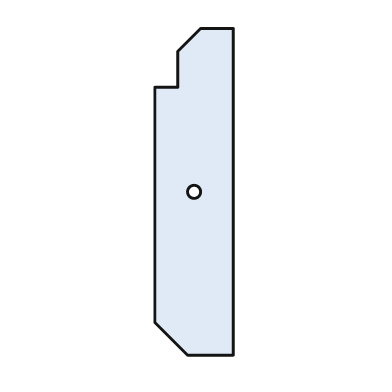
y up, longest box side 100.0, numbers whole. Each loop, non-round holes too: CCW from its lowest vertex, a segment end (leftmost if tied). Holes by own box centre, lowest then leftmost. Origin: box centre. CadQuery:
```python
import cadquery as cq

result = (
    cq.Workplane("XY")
    .moveTo(-2.0, -50.0)
    .lineTo(12.0, -50.0)
    .lineTo(12.0, 50.0)
    .lineTo(2.0, 50.0)
    .lineTo(-5.0, 43.0)
    .lineTo(-5.0, 32.0)
    .lineTo(-12.0, 32.0)
    .lineTo(-12.0, -40.0)
    .close()
    .moveTo(0.0, 0.0)
    .circle(2.0)
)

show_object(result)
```